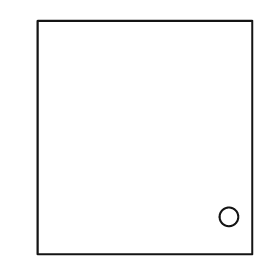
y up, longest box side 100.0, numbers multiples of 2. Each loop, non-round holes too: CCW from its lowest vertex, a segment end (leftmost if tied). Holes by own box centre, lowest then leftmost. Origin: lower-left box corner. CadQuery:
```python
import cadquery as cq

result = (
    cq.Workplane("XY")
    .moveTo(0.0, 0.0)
    .lineTo(92.0, 0.0)
    .lineTo(92.0, 100.0)
    .lineTo(0.0, 100.0)
    .close()
    .moveTo(82.0, 16.0)
    .circle(4.0)
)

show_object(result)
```